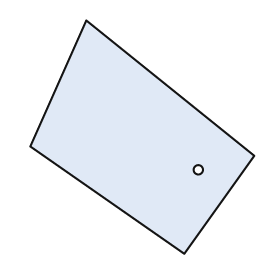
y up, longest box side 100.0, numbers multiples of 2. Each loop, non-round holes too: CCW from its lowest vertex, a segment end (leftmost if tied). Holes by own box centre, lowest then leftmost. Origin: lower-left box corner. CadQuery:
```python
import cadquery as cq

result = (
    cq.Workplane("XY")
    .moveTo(66.0, 0.0)
    .lineTo(96.0, 42.0)
    .lineTo(24.0, 100.0)
    .lineTo(0.0, 46.0)
    .close()
    .moveTo(72.0, 36.0)
    .circle(2.0)
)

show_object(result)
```